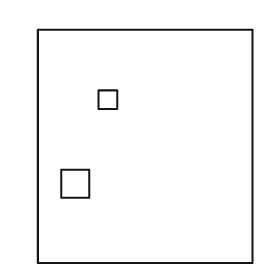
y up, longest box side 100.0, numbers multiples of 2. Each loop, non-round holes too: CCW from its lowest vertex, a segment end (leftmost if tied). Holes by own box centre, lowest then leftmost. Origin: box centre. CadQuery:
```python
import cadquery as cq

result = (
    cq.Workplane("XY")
    .moveTo(-46.0, -50.0)
    .lineTo(46.0, -50.0)
    .lineTo(46.0, 50.0)
    .lineTo(-46.0, 50.0)
    .close()
    .moveTo(-36.0, -22.0)
    .lineTo(-24.0, -22.0)
    .lineTo(-24.0, -10.0)
    .lineTo(-36.0, -10.0)
    .close()
    .moveTo(-20.0, 16.0)
    .lineTo(-12.0, 16.0)
    .lineTo(-12.0, 24.0)
    .lineTo(-20.0, 24.0)
    .close()
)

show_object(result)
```